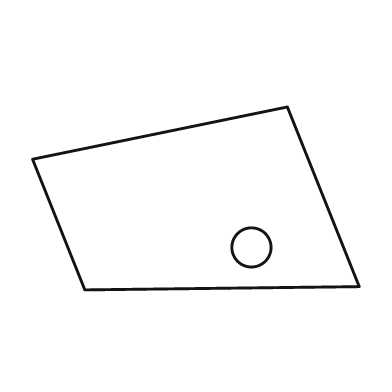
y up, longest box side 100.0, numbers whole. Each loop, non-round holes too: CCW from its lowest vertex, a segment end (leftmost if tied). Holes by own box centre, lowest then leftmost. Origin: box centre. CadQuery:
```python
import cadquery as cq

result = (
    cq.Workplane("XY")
    .moveTo(-34.0, -28.0)
    .lineTo(50.0, -27.0)
    .lineTo(28.0, 28.0)
    .lineTo(-50.0, 12.0)
    .close()
    .moveTo(17.0, -15.0)
    .circle(6.0)
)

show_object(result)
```